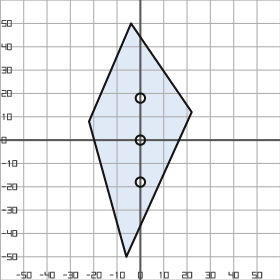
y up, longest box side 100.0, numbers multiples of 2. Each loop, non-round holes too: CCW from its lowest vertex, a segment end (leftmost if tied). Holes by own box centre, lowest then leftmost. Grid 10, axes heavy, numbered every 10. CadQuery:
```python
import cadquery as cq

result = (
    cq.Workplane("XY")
    .moveTo(-6.0, -50.0)
    .lineTo(22.0, 12.0)
    .lineTo(-4.0, 50.0)
    .lineTo(-22.0, 8.0)
    .close()
    .moveTo(0.0, -18.0)
    .circle(2.0)
    .moveTo(0.0, 0.0)
    .circle(2.0)
    .moveTo(0.0, 18.0)
    .circle(2.0)
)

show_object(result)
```